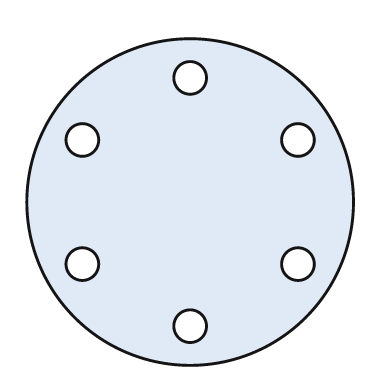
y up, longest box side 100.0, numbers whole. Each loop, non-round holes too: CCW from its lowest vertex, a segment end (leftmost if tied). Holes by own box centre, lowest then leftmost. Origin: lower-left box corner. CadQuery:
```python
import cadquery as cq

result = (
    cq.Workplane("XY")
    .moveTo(50.0, 50.0)
    .circle(50.0)
    .moveTo(50.0, 12.0)
    .circle(5.0)
    .moveTo(17.0, 31.0)
    .circle(5.0)
    .moveTo(83.0, 31.0)
    .circle(5.0)
    .moveTo(17.0, 69.0)
    .circle(5.0)
    .moveTo(83.0, 69.0)
    .circle(5.0)
    .moveTo(50.0, 88.0)
    .circle(5.0)
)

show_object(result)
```